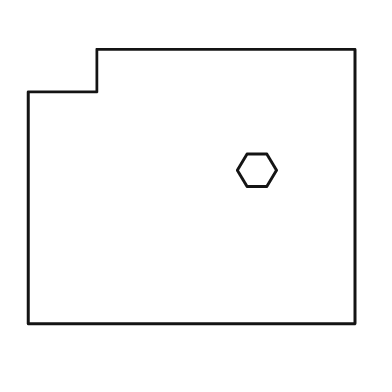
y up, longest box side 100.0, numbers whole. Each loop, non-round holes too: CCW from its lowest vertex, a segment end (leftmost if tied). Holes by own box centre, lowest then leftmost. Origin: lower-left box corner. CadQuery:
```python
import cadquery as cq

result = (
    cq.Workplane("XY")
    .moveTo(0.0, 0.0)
    .lineTo(100.0, 0.0)
    .lineTo(100.0, 84.0)
    .lineTo(21.0, 84.0)
    .lineTo(21.0, 71.0)
    .lineTo(0.0, 71.0)
    .close()
    .moveTo(67.0, 42.0)
    .lineTo(73.0, 42.0)
    .lineTo(76.0, 47.0)
    .lineTo(73.0, 52.0)
    .lineTo(67.0, 52.0)
    .lineTo(64.0, 47.0)
    .close()
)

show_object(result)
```